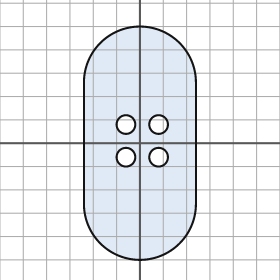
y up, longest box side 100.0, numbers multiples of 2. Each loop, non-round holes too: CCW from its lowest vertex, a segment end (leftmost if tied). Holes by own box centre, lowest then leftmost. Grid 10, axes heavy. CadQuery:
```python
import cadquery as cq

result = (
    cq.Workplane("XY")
    .moveTo(-24.0, -26.0)
    .threePointArc((0.0, -50.0), (24.0, -26.0))
    .lineTo(24.0, 26.0)
    .threePointArc((0.0, 50.0), (-24.0, 26.0))
    .close()
    .moveTo(-6.0, -6.0)
    .circle(4.0)
    .moveTo(8.0, -6.0)
    .circle(4.0)
    .moveTo(-6.0, 8.0)
    .circle(4.0)
    .moveTo(8.0, 8.0)
    .circle(4.0)
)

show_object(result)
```